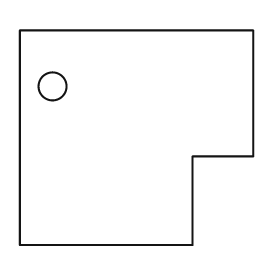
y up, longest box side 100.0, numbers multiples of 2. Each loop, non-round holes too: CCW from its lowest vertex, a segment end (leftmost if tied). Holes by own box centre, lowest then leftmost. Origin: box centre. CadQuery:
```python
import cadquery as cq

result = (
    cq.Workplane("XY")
    .moveTo(-50.0, -46.0)
    .lineTo(24.0, -46.0)
    .lineTo(24.0, -8.0)
    .lineTo(50.0, -8.0)
    .lineTo(50.0, 46.0)
    .lineTo(-50.0, 46.0)
    .close()
    .moveTo(-36.0, 22.0)
    .circle(6.0)
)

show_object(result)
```